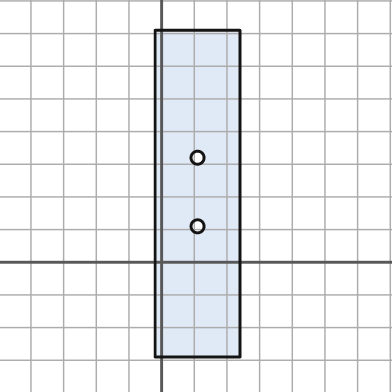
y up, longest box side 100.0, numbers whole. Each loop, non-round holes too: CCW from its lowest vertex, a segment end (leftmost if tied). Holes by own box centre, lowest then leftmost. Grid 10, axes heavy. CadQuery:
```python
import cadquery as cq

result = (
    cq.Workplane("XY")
    .moveTo(-2.0, -29.0)
    .lineTo(24.0, -29.0)
    .lineTo(24.0, 71.0)
    .lineTo(-2.0, 71.0)
    .close()
    .moveTo(11.0, 11.0)
    .circle(2.0)
    .moveTo(11.0, 32.0)
    .circle(2.0)
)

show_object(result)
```